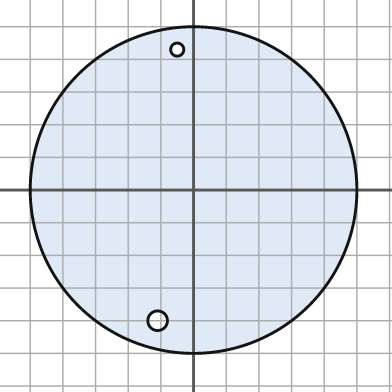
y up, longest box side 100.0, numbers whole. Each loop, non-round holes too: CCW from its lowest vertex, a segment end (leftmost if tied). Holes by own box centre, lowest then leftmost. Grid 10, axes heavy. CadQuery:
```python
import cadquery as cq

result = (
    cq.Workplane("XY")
    .moveTo(0.0, 0.0)
    .circle(50.0)
    .moveTo(-11.0, -40.0)
    .circle(3.0)
    .moveTo(-5.0, 43.0)
    .circle(2.0)
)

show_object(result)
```